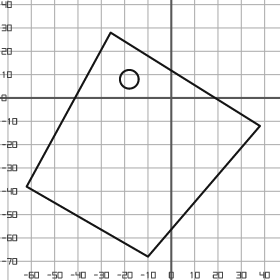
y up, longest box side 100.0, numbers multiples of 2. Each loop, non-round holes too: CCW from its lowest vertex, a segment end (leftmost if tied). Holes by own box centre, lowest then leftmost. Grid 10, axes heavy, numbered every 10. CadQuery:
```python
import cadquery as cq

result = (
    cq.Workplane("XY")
    .moveTo(-10.0, -68.0)
    .lineTo(38.0, -12.0)
    .lineTo(-26.0, 28.0)
    .lineTo(-62.0, -38.0)
    .close()
    .moveTo(-18.0, 8.0)
    .circle(4.0)
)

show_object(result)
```